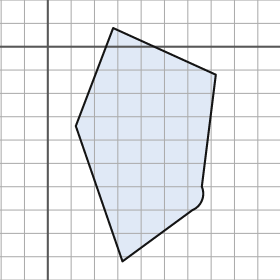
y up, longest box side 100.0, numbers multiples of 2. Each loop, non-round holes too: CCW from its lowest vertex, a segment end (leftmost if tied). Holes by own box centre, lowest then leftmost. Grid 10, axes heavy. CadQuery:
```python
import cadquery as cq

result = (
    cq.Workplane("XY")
    .moveTo(32.0, -92.0)
    .lineTo(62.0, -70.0)
    .threePointArc((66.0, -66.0), (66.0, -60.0))
    .lineTo(72.0, -12.0)
    .lineTo(28.0, 8.0)
    .lineTo(12.0, -34.0)
    .close()
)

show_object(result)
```